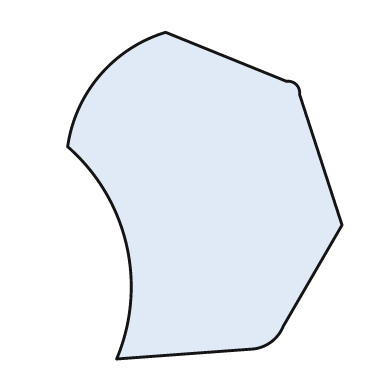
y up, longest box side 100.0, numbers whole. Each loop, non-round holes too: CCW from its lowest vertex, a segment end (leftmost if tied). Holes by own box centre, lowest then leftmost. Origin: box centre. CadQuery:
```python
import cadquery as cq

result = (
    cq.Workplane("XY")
    .moveTo(-27.0, -50.0)
    .lineTo(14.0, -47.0)
    .threePointArc((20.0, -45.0), (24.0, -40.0))
    .lineTo(42.0, -9.0)
    .lineTo(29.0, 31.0)
    .threePointArc((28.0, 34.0), (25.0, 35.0))
    .lineTo(-12.0, 50.0)
    .threePointArc((-32.0, 37.0), (-42.0, 15.0))
    .threePointArc((-24.0, -15.0), (-27.0, -50.0))
    .close()
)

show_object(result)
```